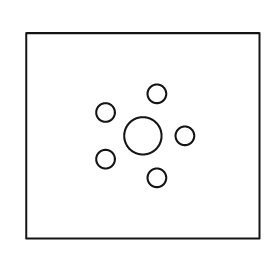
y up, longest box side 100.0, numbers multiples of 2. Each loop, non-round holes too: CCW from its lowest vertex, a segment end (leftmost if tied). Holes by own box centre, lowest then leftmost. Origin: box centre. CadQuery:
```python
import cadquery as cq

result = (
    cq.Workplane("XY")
    .moveTo(-50.0, -44.0)
    .lineTo(50.0, -44.0)
    .lineTo(50.0, 44.0)
    .lineTo(-50.0, 44.0)
    .close()
    .moveTo(6.0, -18.0)
    .circle(4.0)
    .moveTo(-16.0, -10.0)
    .circle(4.0)
    .moveTo(0.0, 0.0)
    .circle(8.0)
    .moveTo(18.0, 0.0)
    .circle(4.0)
    .moveTo(-16.0, 10.0)
    .circle(4.0)
    .moveTo(6.0, 18.0)
    .circle(4.0)
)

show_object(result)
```